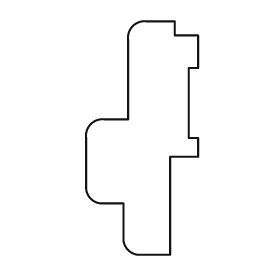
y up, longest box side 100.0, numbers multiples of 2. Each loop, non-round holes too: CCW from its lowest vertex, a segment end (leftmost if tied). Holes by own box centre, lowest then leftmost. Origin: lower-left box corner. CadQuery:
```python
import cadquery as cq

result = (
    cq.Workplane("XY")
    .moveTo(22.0, 0.0)
    .lineTo(36.0, 0.0)
    .lineTo(36.0, 42.0)
    .lineTo(48.0, 42.0)
    .lineTo(48.0, 50.0)
    .lineTo(44.0, 50.0)
    .lineTo(44.0, 80.0)
    .lineTo(48.0, 80.0)
    .lineTo(48.0, 94.0)
    .lineTo(38.0, 94.0)
    .lineTo(38.0, 100.0)
    .lineTo(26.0, 100.0)
    .threePointArc((20.0, 98.0), (18.0, 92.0))
    .lineTo(18.0, 58.0)
    .lineTo(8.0, 58.0)
    .threePointArc((2.0, 56.0), (0.0, 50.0))
    .lineTo(0.0, 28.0)
    .threePointArc((2.0, 24.0), (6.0, 22.0))
    .lineTo(16.0, 22.0)
    .lineTo(16.0, 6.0)
    .threePointArc((18.0, 2.0), (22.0, 0.0))
    .close()
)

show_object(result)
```